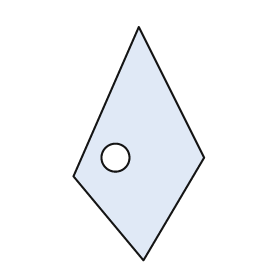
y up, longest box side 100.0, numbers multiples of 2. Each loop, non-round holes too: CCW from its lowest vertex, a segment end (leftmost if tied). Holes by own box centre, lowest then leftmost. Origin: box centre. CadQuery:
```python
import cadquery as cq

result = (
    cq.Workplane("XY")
    .moveTo(2.0, -50.0)
    .lineTo(28.0, -6.0)
    .lineTo(0.0, 50.0)
    .lineTo(-28.0, -14.0)
    .close()
    .moveTo(-10.0, -6.0)
    .circle(6.0)
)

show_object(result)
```